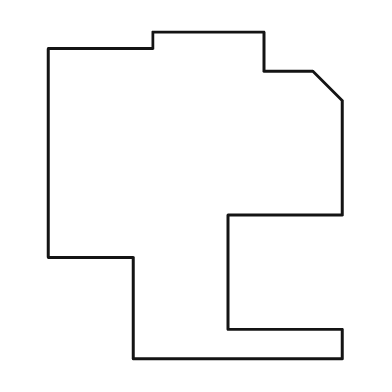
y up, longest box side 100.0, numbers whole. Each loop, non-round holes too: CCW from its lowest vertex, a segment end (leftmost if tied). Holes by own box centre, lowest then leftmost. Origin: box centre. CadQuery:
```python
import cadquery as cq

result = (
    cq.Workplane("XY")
    .moveTo(-19.0, -50.0)
    .lineTo(45.0, -50.0)
    .lineTo(45.0, -41.0)
    .lineTo(10.0, -41.0)
    .lineTo(10.0, -6.0)
    .lineTo(45.0, -6.0)
    .lineTo(45.0, 29.0)
    .lineTo(36.0, 38.0)
    .lineTo(21.0, 38.0)
    .lineTo(21.0, 50.0)
    .lineTo(-13.0, 50.0)
    .lineTo(-13.0, 45.0)
    .lineTo(-45.0, 45.0)
    .lineTo(-45.0, -19.0)
    .lineTo(-19.0, -19.0)
    .close()
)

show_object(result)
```